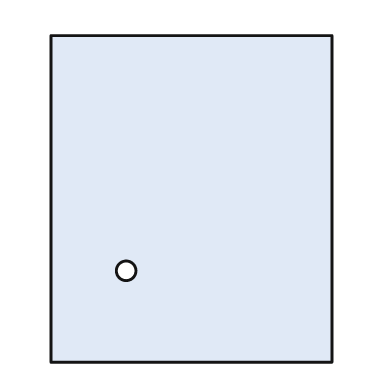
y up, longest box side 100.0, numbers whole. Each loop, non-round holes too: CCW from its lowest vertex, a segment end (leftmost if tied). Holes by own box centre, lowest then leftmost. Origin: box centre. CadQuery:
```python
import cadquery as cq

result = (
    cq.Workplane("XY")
    .moveTo(-43.0, -50.0)
    .lineTo(43.0, -50.0)
    .lineTo(43.0, 50.0)
    .lineTo(-43.0, 50.0)
    .close()
    .moveTo(-20.0, -22.0)
    .circle(3.0)
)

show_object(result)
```